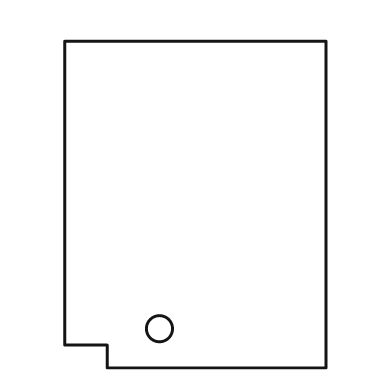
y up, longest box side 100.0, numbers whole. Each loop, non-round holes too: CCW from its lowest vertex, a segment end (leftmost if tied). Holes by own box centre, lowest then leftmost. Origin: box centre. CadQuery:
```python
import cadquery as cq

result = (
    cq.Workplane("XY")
    .moveTo(-27.0, -50.0)
    .lineTo(40.0, -50.0)
    .lineTo(40.0, 50.0)
    .lineTo(-40.0, 50.0)
    .lineTo(-40.0, -43.0)
    .lineTo(-27.0, -43.0)
    .close()
    .moveTo(-11.0, -38.0)
    .circle(4.0)
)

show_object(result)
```